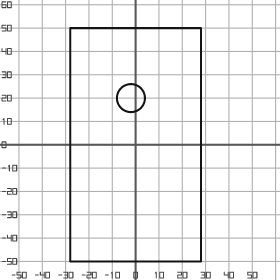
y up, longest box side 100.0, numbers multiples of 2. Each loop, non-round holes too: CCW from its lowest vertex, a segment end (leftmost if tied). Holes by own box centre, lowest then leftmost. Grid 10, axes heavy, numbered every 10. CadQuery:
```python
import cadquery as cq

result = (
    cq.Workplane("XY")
    .moveTo(-28.0, -50.0)
    .lineTo(28.0, -50.0)
    .lineTo(28.0, 50.0)
    .lineTo(-28.0, 50.0)
    .close()
    .moveTo(-2.0, 20.0)
    .circle(6.0)
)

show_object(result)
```